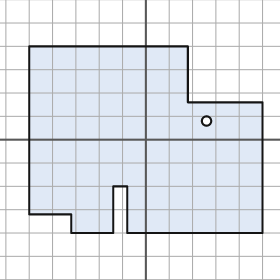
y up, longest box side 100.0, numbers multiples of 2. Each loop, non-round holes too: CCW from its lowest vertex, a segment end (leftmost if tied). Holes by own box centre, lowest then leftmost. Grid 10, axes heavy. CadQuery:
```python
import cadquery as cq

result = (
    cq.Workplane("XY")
    .moveTo(-32.0, -40.0)
    .lineTo(-14.0, -40.0)
    .lineTo(-14.0, -20.0)
    .lineTo(-8.0, -20.0)
    .lineTo(-8.0, -40.0)
    .lineTo(50.0, -40.0)
    .lineTo(50.0, 16.0)
    .lineTo(18.0, 16.0)
    .lineTo(18.0, 40.0)
    .lineTo(-50.0, 40.0)
    .lineTo(-50.0, -32.0)
    .lineTo(-32.0, -32.0)
    .close()
    .moveTo(26.0, 8.0)
    .circle(2.0)
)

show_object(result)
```